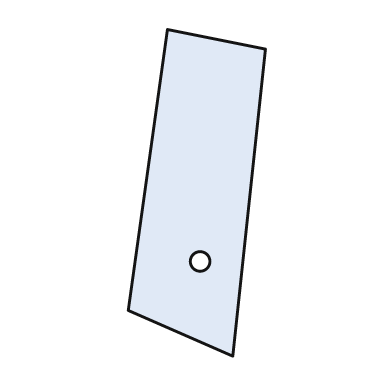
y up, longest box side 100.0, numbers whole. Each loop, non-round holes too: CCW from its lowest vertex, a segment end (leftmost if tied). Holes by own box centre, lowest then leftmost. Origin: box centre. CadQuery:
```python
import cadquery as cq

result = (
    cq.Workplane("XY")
    .moveTo(11.0, -50.0)
    .lineTo(21.0, 44.0)
    .lineTo(-9.0, 50.0)
    .lineTo(-21.0, -36.0)
    .close()
    .moveTo(1.0, -21.0)
    .circle(3.0)
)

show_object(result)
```